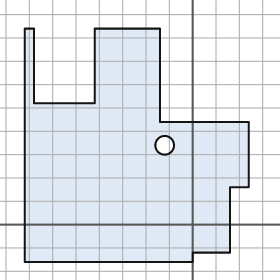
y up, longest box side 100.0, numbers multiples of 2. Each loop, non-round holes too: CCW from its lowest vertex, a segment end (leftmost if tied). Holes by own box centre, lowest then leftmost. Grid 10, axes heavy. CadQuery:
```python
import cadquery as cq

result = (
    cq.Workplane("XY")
    .moveTo(-72.0, -16.0)
    .lineTo(0.0, -16.0)
    .lineTo(0.0, -12.0)
    .lineTo(16.0, -12.0)
    .lineTo(16.0, 16.0)
    .lineTo(24.0, 16.0)
    .lineTo(24.0, 44.0)
    .lineTo(-14.0, 44.0)
    .lineTo(-14.0, 84.0)
    .lineTo(-42.0, 84.0)
    .lineTo(-42.0, 52.0)
    .lineTo(-68.0, 52.0)
    .lineTo(-68.0, 84.0)
    .lineTo(-72.0, 84.0)
    .close()
    .moveTo(-12.0, 34.0)
    .circle(4.0)
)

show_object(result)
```